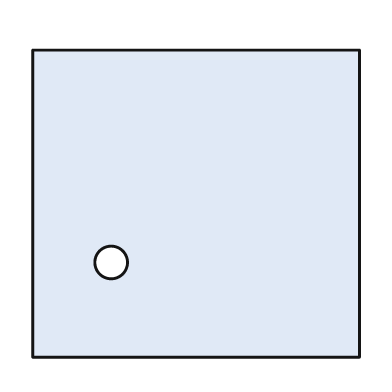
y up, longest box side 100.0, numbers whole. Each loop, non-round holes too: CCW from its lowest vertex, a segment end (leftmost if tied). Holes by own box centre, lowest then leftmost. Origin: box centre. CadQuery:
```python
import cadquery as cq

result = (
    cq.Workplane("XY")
    .moveTo(-50.0, -47.0)
    .lineTo(50.0, -47.0)
    .lineTo(50.0, 47.0)
    .lineTo(-50.0, 47.0)
    .close()
    .moveTo(-26.0, -18.0)
    .circle(5.0)
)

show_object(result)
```